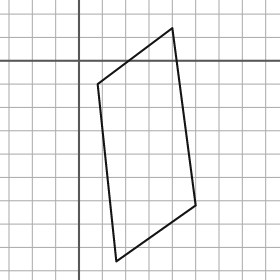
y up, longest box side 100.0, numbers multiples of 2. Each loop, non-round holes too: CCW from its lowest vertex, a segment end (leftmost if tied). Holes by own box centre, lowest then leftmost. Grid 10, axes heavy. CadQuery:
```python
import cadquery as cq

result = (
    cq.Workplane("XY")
    .moveTo(16.0, -86.0)
    .lineTo(50.0, -62.0)
    .lineTo(40.0, 14.0)
    .lineTo(8.0, -10.0)
    .close()
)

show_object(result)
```